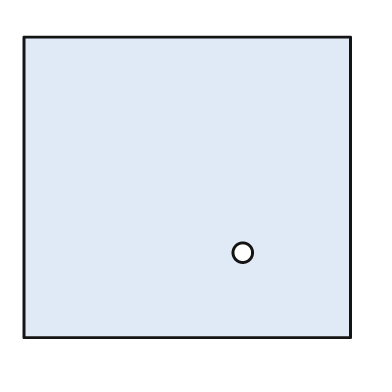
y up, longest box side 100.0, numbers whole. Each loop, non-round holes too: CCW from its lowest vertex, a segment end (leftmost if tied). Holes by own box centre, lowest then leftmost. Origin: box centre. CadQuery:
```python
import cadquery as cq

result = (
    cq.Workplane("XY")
    .moveTo(-50.0, -46.0)
    .lineTo(50.0, -46.0)
    .lineTo(50.0, 46.0)
    .lineTo(-50.0, 46.0)
    .close()
    .moveTo(17.0, -20.0)
    .circle(3.0)
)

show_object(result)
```